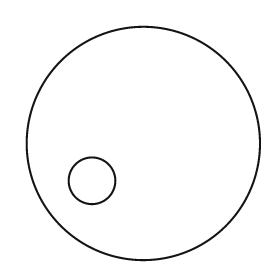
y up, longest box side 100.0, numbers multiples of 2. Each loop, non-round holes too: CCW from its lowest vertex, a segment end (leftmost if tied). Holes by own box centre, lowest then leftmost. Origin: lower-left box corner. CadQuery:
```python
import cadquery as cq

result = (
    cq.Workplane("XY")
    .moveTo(50.0, 50.0)
    .circle(50.0)
    .moveTo(28.0, 34.0)
    .circle(10.0)
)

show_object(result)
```